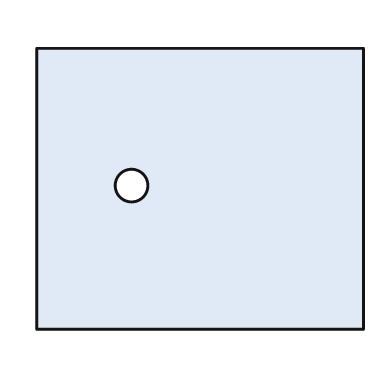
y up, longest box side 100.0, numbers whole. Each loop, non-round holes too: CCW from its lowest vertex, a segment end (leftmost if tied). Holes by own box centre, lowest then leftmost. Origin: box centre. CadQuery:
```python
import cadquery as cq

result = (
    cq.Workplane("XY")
    .moveTo(-50.0, -43.0)
    .lineTo(50.0, -43.0)
    .lineTo(50.0, 43.0)
    .lineTo(-50.0, 43.0)
    .close()
    .moveTo(-21.0, 1.0)
    .circle(5.0)
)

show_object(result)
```